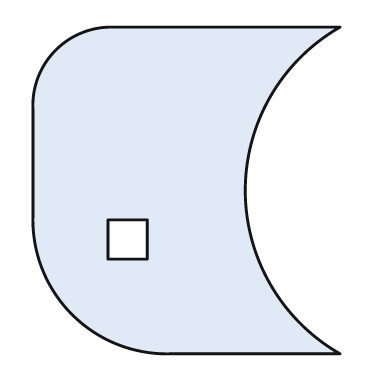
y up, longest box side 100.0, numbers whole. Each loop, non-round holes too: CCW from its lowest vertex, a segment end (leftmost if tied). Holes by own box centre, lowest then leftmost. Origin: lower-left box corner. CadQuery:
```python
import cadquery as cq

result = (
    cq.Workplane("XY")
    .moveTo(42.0, 0.0)
    .lineTo(94.0, 0.0)
    .threePointArc((65.0, 50.0), (94.0, 100.0))
    .lineTo(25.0, 100.0)
    .threePointArc((7.0, 93.0), (0.0, 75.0))
    .lineTo(0.0, 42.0)
    .threePointArc((12.0, 12.0), (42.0, 0.0))
    .close()
    .moveTo(23.0, 29.0)
    .lineTo(35.0, 29.0)
    .lineTo(35.0, 41.0)
    .lineTo(23.0, 41.0)
    .close()
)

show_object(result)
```